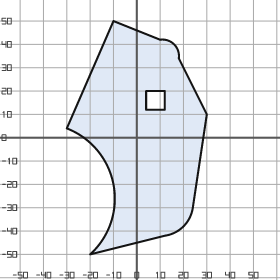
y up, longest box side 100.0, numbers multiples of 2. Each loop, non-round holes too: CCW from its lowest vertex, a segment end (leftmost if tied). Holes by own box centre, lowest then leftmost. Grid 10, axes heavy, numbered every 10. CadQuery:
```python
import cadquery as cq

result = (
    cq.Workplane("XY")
    .moveTo(-20.0, -50.0)
    .lineTo(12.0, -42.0)
    .threePointArc((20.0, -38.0), (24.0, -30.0))
    .lineTo(30.0, 10.0)
    .lineTo(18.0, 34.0)
    .threePointArc((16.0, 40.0), (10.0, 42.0))
    .lineTo(-10.0, 50.0)
    .lineTo(-30.0, 4.0)
    .threePointArc((-10.0, -20.0), (-20.0, -50.0))
    .close()
    .moveTo(4.0, 12.0)
    .lineTo(12.0, 12.0)
    .lineTo(12.0, 20.0)
    .lineTo(4.0, 20.0)
    .close()
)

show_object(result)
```